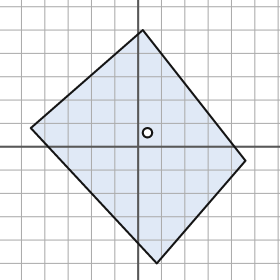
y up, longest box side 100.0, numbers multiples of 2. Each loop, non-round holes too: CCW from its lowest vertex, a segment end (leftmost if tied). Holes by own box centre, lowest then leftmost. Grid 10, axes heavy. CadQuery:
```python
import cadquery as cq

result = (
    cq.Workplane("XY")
    .moveTo(8.0, -50.0)
    .lineTo(46.0, -6.0)
    .lineTo(2.0, 50.0)
    .lineTo(-46.0, 8.0)
    .close()
    .moveTo(4.0, 6.0)
    .circle(2.0)
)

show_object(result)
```